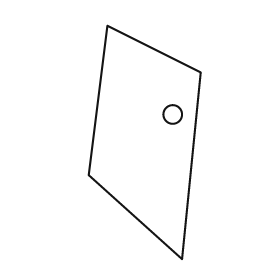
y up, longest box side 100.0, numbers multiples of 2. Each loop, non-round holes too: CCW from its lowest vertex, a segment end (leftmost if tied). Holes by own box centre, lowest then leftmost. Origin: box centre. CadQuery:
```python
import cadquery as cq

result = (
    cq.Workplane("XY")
    .moveTo(16.0, -50.0)
    .lineTo(24.0, 30.0)
    .lineTo(-16.0, 50.0)
    .lineTo(-24.0, -14.0)
    .close()
    .moveTo(12.0, 12.0)
    .circle(4.0)
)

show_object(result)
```